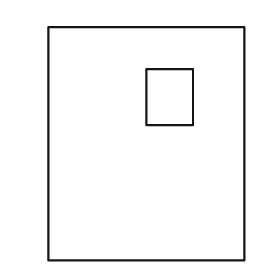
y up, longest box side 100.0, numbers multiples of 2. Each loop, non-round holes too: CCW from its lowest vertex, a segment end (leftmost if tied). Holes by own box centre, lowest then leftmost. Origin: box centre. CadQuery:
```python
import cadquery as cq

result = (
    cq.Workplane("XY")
    .moveTo(-42.0, -50.0)
    .lineTo(42.0, -50.0)
    .lineTo(42.0, 50.0)
    .lineTo(-42.0, 50.0)
    .close()
    .moveTo(0.0, 8.0)
    .lineTo(20.0, 8.0)
    .lineTo(20.0, 32.0)
    .lineTo(0.0, 32.0)
    .close()
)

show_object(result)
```